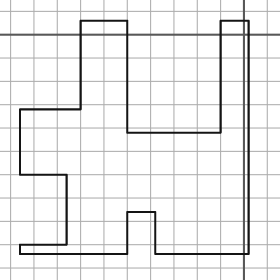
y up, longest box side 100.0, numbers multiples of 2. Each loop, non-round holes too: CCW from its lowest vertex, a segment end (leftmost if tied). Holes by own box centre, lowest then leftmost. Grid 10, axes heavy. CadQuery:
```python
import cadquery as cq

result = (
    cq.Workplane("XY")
    .moveTo(-96.0, -94.0)
    .lineTo(-50.0, -94.0)
    .lineTo(-50.0, -76.0)
    .lineTo(-38.0, -76.0)
    .lineTo(-38.0, -94.0)
    .lineTo(2.0, -94.0)
    .lineTo(2.0, 6.0)
    .lineTo(-10.0, 6.0)
    .lineTo(-10.0, -42.0)
    .lineTo(-50.0, -42.0)
    .lineTo(-50.0, 6.0)
    .lineTo(-70.0, 6.0)
    .lineTo(-70.0, -32.0)
    .lineTo(-96.0, -32.0)
    .lineTo(-96.0, -60.0)
    .lineTo(-76.0, -60.0)
    .lineTo(-76.0, -90.0)
    .lineTo(-96.0, -90.0)
    .close()
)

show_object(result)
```